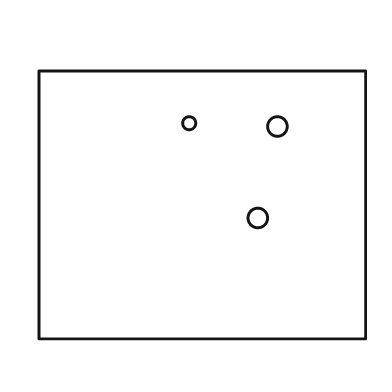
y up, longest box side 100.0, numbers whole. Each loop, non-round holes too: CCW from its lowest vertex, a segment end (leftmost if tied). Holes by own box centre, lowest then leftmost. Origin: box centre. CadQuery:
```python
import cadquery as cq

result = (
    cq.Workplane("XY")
    .moveTo(-50.0, -41.0)
    .lineTo(50.0, -41.0)
    .lineTo(50.0, 41.0)
    .lineTo(-50.0, 41.0)
    .close()
    .moveTo(17.0, -4.0)
    .circle(3.0)
    .moveTo(23.0, 24.0)
    .circle(3.0)
    .moveTo(-4.0, 25.0)
    .circle(2.0)
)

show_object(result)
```